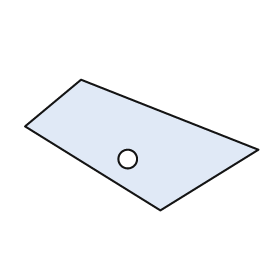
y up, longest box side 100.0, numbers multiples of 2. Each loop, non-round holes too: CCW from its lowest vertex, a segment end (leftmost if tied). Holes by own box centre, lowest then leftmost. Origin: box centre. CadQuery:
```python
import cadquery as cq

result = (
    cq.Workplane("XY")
    .moveTo(8.0, -28.0)
    .lineTo(50.0, -2.0)
    .lineTo(-26.0, 28.0)
    .lineTo(-50.0, 8.0)
    .close()
    .moveTo(-6.0, -6.0)
    .circle(4.0)
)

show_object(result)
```